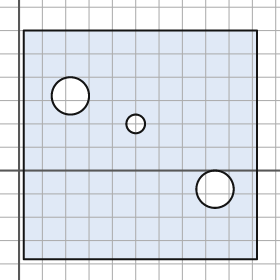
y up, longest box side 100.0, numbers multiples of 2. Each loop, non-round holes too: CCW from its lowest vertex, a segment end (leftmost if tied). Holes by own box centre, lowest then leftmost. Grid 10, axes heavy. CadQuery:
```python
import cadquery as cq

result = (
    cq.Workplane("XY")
    .moveTo(2.0, -38.0)
    .lineTo(102.0, -38.0)
    .lineTo(102.0, 60.0)
    .lineTo(2.0, 60.0)
    .close()
    .moveTo(84.0, -8.0)
    .circle(8.0)
    .moveTo(50.0, 20.0)
    .circle(4.0)
    .moveTo(22.0, 32.0)
    .circle(8.0)
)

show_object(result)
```